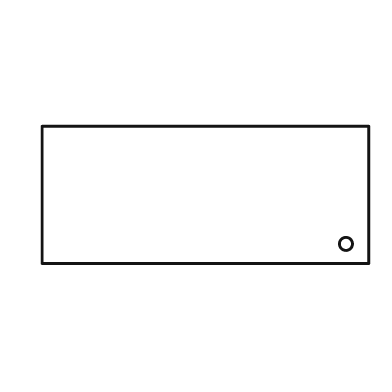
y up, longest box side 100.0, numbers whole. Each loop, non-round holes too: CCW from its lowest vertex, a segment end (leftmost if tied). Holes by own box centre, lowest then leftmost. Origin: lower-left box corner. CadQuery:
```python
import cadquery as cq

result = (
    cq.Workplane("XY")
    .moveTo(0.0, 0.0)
    .lineTo(100.0, 0.0)
    .lineTo(100.0, 42.0)
    .lineTo(0.0, 42.0)
    .close()
    .moveTo(93.0, 6.0)
    .circle(2.0)
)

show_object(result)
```